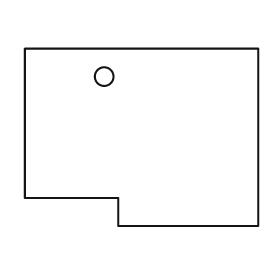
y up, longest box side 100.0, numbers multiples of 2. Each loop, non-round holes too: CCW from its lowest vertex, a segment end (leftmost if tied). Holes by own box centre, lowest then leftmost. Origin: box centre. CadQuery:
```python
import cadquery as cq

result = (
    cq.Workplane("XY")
    .moveTo(-10.0, -38.0)
    .lineTo(50.0, -38.0)
    .lineTo(50.0, 38.0)
    .lineTo(-50.0, 38.0)
    .lineTo(-50.0, -26.0)
    .lineTo(-10.0, -26.0)
    .close()
    .moveTo(-16.0, 26.0)
    .circle(4.0)
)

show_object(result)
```